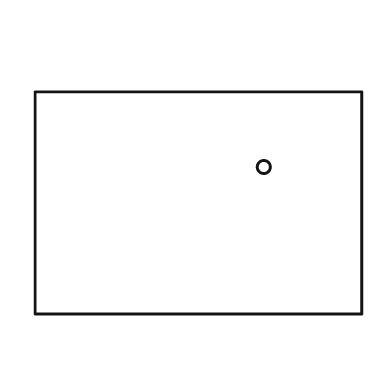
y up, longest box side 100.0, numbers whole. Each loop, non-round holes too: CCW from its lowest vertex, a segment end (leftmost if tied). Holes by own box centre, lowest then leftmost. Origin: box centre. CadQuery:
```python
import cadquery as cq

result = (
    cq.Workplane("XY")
    .moveTo(-50.0, -34.0)
    .lineTo(50.0, -34.0)
    .lineTo(50.0, 34.0)
    .lineTo(-50.0, 34.0)
    .close()
    .moveTo(20.0, 11.0)
    .circle(2.0)
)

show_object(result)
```